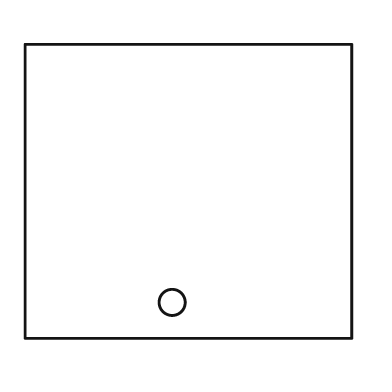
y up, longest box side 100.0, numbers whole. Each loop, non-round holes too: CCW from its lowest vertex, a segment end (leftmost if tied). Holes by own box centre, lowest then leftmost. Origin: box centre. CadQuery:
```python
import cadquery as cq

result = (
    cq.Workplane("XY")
    .moveTo(-50.0, -45.0)
    .lineTo(50.0, -45.0)
    .lineTo(50.0, 45.0)
    .lineTo(-50.0, 45.0)
    .close()
    .moveTo(-5.0, -34.0)
    .circle(4.0)
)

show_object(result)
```